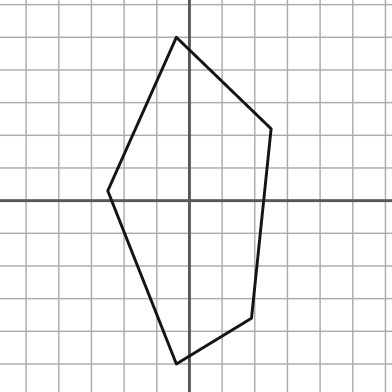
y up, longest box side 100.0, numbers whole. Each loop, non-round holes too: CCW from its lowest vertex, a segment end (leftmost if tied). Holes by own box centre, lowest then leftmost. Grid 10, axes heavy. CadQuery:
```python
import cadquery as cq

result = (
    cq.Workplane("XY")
    .moveTo(-4.0, -50.0)
    .lineTo(19.0, -36.0)
    .lineTo(25.0, 22.0)
    .lineTo(-4.0, 50.0)
    .lineTo(-25.0, 3.0)
    .close()
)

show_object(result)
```